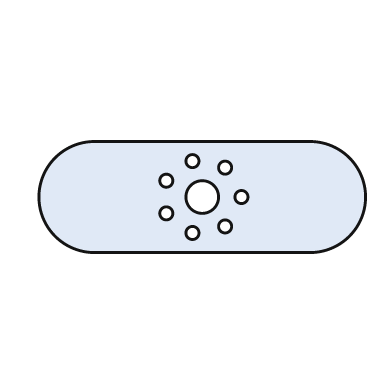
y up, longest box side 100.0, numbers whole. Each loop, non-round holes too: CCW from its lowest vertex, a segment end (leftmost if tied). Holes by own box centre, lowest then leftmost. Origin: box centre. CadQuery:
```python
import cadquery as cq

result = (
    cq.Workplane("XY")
    .moveTo(-33.0, -17.0)
    .lineTo(33.0, -17.0)
    .threePointArc((50.0, 0.0), (33.0, 17.0))
    .lineTo(-33.0, 17.0)
    .threePointArc((-50.0, 0.0), (-33.0, -17.0))
    .close()
    .moveTo(-3.0, -11.0)
    .circle(2.0)
    .moveTo(7.0, -9.0)
    .circle(2.0)
    .moveTo(-11.0, -5.0)
    .circle(2.0)
    .moveTo(0.0, 0.0)
    .circle(5.0)
    .moveTo(12.0, 0.0)
    .circle(2.0)
    .moveTo(-11.0, 5.0)
    .circle(2.0)
    .moveTo(7.0, 9.0)
    .circle(2.0)
    .moveTo(-3.0, 11.0)
    .circle(2.0)
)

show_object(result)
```